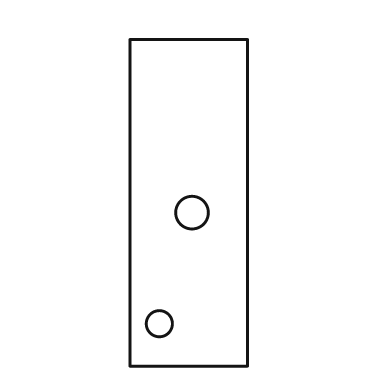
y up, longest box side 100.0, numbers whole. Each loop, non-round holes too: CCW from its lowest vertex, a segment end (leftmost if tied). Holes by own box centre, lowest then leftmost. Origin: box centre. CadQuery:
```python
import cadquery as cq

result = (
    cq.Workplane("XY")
    .moveTo(-18.0, -50.0)
    .lineTo(18.0, -50.0)
    .lineTo(18.0, 50.0)
    .lineTo(-18.0, 50.0)
    .close()
    .moveTo(-9.0, -37.0)
    .circle(4.0)
    .moveTo(1.0, -3.0)
    .circle(5.0)
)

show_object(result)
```